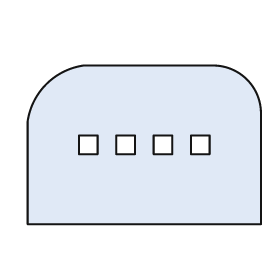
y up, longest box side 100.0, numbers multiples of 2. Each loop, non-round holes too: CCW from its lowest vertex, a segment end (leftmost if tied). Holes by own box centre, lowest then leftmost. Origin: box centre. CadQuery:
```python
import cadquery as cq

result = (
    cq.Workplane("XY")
    .moveTo(-50.0, -34.0)
    .lineTo(50.0, -34.0)
    .lineTo(50.0, 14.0)
    .threePointArc((44.0, 28.0), (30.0, 34.0))
    .lineTo(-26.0, 34.0)
    .threePointArc((-42.0, 26.0), (-50.0, 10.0))
    .close()
    .moveTo(-28.0, -4.0)
    .lineTo(-20.0, -4.0)
    .lineTo(-20.0, 4.0)
    .lineTo(-28.0, 4.0)
    .close()
    .moveTo(-12.0, -4.0)
    .lineTo(-4.0, -4.0)
    .lineTo(-4.0, 4.0)
    .lineTo(-12.0, 4.0)
    .close()
    .moveTo(4.0, -4.0)
    .lineTo(12.0, -4.0)
    .lineTo(12.0, 4.0)
    .lineTo(4.0, 4.0)
    .close()
    .moveTo(20.0, -4.0)
    .lineTo(28.0, -4.0)
    .lineTo(28.0, 4.0)
    .lineTo(20.0, 4.0)
    .close()
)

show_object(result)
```